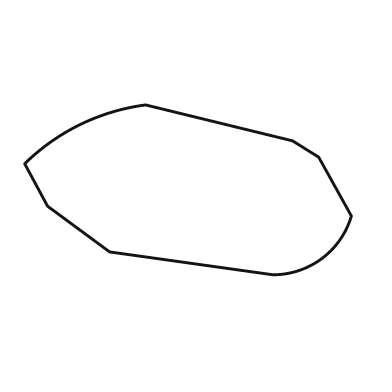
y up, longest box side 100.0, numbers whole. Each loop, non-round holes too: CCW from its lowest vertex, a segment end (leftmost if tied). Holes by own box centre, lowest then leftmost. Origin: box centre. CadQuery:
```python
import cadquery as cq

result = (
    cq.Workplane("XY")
    .moveTo(26.0, -26.0)
    .threePointArc((41.0, -21.0), (50.0, -8.0))
    .lineTo(40.0, 10.0)
    .lineTo(32.0, 15.0)
    .lineTo(-13.0, 26.0)
    .threePointArc((-33.0, 20.0), (-50.0, 8.0))
    .lineTo(-43.0, -5.0)
    .lineTo(-24.0, -19.0)
    .close()
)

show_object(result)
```